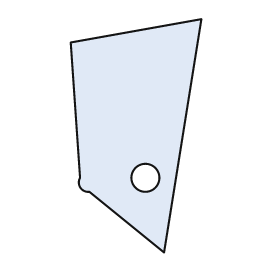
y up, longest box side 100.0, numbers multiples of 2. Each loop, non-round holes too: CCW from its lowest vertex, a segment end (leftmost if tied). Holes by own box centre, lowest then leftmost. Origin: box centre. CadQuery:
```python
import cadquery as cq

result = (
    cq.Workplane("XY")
    .moveTo(12.0, -50.0)
    .lineTo(28.0, 50.0)
    .lineTo(-28.0, 40.0)
    .lineTo(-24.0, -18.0)
    .threePointArc((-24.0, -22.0), (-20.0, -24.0))
    .close()
    .moveTo(4.0, -18.0)
    .circle(6.0)
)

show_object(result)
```